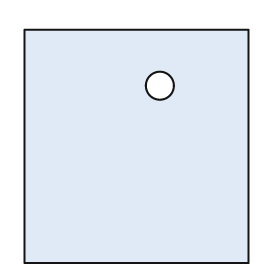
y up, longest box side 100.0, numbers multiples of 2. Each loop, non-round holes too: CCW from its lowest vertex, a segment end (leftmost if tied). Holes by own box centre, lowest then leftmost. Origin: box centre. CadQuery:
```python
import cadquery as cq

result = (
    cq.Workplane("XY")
    .moveTo(-48.0, -50.0)
    .lineTo(48.0, -50.0)
    .lineTo(48.0, 50.0)
    .lineTo(-48.0, 50.0)
    .close()
    .moveTo(10.0, 26.0)
    .circle(6.0)
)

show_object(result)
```